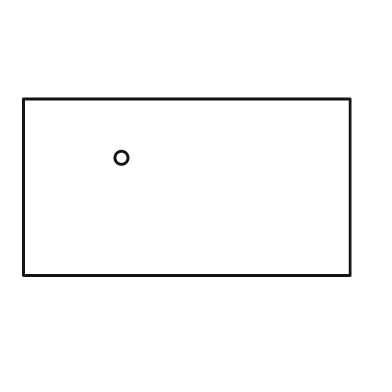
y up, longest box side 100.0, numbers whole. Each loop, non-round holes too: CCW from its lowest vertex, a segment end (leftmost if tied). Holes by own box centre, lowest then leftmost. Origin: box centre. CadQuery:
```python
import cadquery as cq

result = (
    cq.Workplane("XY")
    .moveTo(-50.0, -27.0)
    .lineTo(50.0, -27.0)
    .lineTo(50.0, 27.0)
    .lineTo(-50.0, 27.0)
    .close()
    .moveTo(-20.0, 9.0)
    .circle(2.0)
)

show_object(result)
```